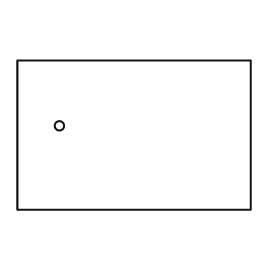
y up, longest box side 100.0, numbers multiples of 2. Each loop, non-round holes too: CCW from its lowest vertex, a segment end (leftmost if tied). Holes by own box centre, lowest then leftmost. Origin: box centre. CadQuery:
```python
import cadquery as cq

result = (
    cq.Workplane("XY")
    .moveTo(-50.0, -32.0)
    .lineTo(50.0, -32.0)
    .lineTo(50.0, 32.0)
    .lineTo(-50.0, 32.0)
    .close()
    .moveTo(-32.0, 4.0)
    .circle(2.0)
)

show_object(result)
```